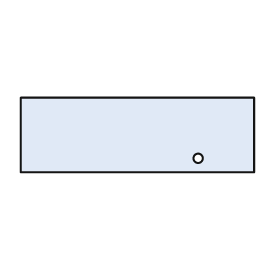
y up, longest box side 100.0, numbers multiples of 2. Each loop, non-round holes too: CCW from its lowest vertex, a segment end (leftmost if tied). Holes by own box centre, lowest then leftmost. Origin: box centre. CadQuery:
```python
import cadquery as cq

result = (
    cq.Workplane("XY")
    .moveTo(-50.0, -16.0)
    .lineTo(50.0, -16.0)
    .lineTo(50.0, 16.0)
    .lineTo(-50.0, 16.0)
    .close()
    .moveTo(26.0, -10.0)
    .circle(2.0)
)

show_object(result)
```